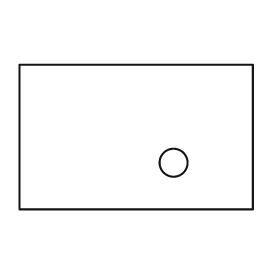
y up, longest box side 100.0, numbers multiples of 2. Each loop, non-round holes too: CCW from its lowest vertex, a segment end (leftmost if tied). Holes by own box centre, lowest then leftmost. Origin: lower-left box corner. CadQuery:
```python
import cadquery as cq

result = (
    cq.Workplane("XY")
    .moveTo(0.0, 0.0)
    .lineTo(100.0, 0.0)
    .lineTo(100.0, 62.0)
    .lineTo(0.0, 62.0)
    .close()
    .moveTo(66.0, 20.0)
    .circle(6.0)
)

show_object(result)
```